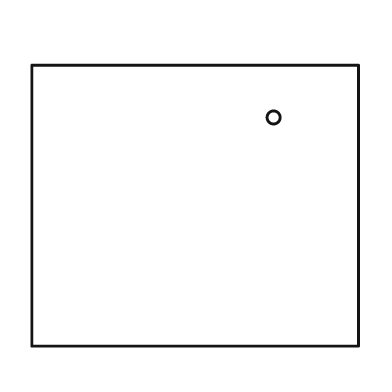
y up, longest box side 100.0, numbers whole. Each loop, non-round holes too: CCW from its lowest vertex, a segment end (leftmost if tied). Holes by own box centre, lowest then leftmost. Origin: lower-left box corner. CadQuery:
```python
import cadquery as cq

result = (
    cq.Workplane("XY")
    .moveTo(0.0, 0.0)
    .lineTo(100.0, 0.0)
    .lineTo(100.0, 86.0)
    .lineTo(0.0, 86.0)
    .close()
    .moveTo(74.0, 70.0)
    .circle(2.0)
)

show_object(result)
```